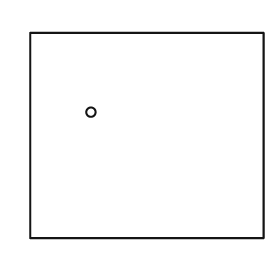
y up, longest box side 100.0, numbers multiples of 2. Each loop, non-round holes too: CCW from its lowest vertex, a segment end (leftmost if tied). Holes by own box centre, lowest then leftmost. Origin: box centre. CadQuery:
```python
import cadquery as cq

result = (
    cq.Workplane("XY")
    .moveTo(-50.0, -44.0)
    .lineTo(50.0, -44.0)
    .lineTo(50.0, 44.0)
    .lineTo(-50.0, 44.0)
    .close()
    .moveTo(-24.0, 10.0)
    .circle(2.0)
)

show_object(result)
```